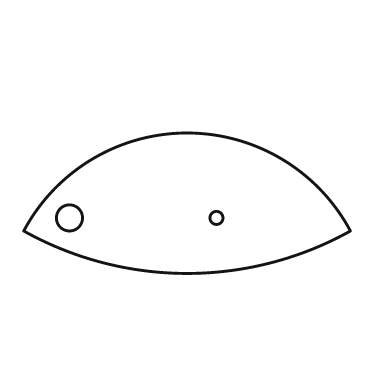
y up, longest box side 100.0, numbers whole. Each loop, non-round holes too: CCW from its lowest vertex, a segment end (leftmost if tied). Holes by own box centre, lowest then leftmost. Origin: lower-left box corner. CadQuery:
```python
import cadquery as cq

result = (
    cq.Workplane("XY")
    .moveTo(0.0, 13.0)
    .threePointArc((50.0, 0.0), (100.0, 13.0))
    .threePointArc((50.0, 43.0), (0.0, 13.0))
    .close()
    .moveTo(14.0, 17.0)
    .circle(4.0)
    .moveTo(59.0, 17.0)
    .circle(2.0)
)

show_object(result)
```